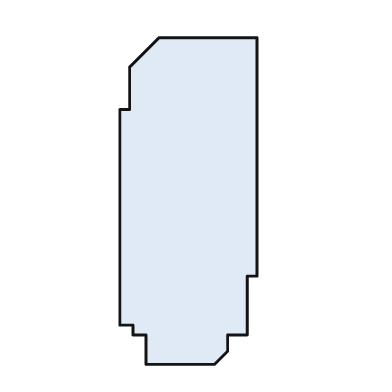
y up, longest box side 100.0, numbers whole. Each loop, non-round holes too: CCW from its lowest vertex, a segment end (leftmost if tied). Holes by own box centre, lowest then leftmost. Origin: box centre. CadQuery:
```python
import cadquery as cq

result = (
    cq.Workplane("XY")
    .moveTo(-13.0, -50.0)
    .lineTo(8.0, -50.0)
    .lineTo(12.0, -46.0)
    .lineTo(12.0, -41.0)
    .lineTo(18.0, -41.0)
    .lineTo(18.0, -23.0)
    .lineTo(21.0, -23.0)
    .lineTo(21.0, 50.0)
    .lineTo(-9.0, 50.0)
    .lineTo(-18.0, 41.0)
    .lineTo(-18.0, 28.0)
    .lineTo(-21.0, 28.0)
    .lineTo(-21.0, -38.0)
    .lineTo(-17.0, -38.0)
    .lineTo(-17.0, -41.0)
    .lineTo(-13.0, -41.0)
    .close()
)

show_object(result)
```